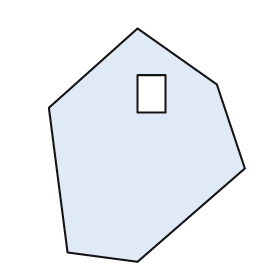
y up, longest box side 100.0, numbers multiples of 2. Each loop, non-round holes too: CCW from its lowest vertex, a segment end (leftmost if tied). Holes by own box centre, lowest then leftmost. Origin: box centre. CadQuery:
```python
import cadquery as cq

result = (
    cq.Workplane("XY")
    .moveTo(-4.0, -50.0)
    .lineTo(42.0, -10.0)
    .lineTo(30.0, 26.0)
    .lineTo(-4.0, 50.0)
    .lineTo(-42.0, 16.0)
    .lineTo(-34.0, -46.0)
    .close()
    .moveTo(-4.0, 14.0)
    .lineTo(8.0, 14.0)
    .lineTo(8.0, 30.0)
    .lineTo(-4.0, 30.0)
    .close()
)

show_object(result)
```